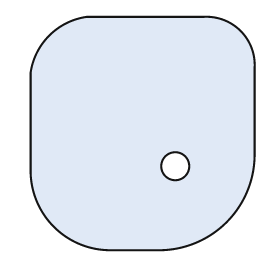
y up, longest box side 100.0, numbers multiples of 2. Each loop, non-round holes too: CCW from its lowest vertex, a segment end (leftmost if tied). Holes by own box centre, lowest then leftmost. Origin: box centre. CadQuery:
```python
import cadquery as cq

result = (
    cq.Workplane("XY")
    .moveTo(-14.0, -50.0)
    .lineTo(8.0, -50.0)
    .threePointArc((36.0, -38.0), (48.0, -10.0))
    .lineTo(48.0, 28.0)
    .threePointArc((42.0, 44.0), (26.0, 50.0))
    .lineTo(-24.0, 50.0)
    .threePointArc((-40.0, 42.0), (-48.0, 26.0))
    .lineTo(-48.0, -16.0)
    .threePointArc((-38.0, -40.0), (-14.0, -50.0))
    .close()
    .moveTo(14.0, -14.0)
    .circle(6.0)
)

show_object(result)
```